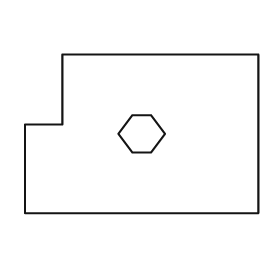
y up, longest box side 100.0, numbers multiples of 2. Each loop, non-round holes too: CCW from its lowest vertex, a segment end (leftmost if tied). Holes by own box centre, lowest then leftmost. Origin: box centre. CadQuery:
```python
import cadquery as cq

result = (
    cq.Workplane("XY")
    .moveTo(-50.0, -34.0)
    .lineTo(50.0, -34.0)
    .lineTo(50.0, 34.0)
    .lineTo(-34.0, 34.0)
    .lineTo(-34.0, 4.0)
    .lineTo(-50.0, 4.0)
    .close()
    .moveTo(-4.0, -8.0)
    .lineTo(4.0, -8.0)
    .lineTo(10.0, 0.0)
    .lineTo(4.0, 8.0)
    .lineTo(-4.0, 8.0)
    .lineTo(-10.0, 0.0)
    .close()
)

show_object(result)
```